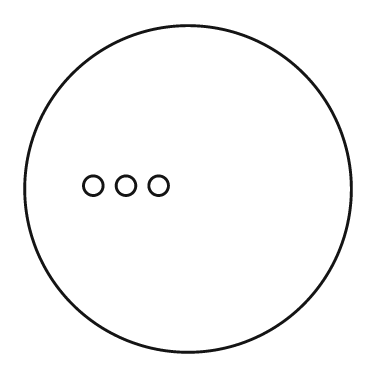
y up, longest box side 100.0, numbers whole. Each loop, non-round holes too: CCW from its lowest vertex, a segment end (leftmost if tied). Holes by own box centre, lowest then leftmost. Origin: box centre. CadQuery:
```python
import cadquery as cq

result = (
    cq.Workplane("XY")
    .moveTo(0.0, 0.0)
    .circle(50.0)
    .moveTo(-29.0, 1.0)
    .circle(3.0)
    .moveTo(-19.0, 1.0)
    .circle(3.0)
    .moveTo(-9.0, 1.0)
    .circle(3.0)
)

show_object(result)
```